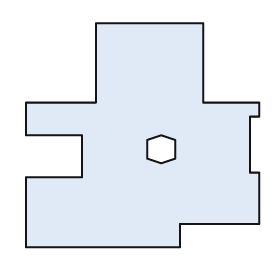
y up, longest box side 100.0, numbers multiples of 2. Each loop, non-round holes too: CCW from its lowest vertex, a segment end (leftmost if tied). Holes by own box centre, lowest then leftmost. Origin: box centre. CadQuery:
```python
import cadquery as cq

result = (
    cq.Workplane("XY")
    .moveTo(-50.0, -48.0)
    .lineTo(16.0, -48.0)
    .lineTo(16.0, -38.0)
    .lineTo(50.0, -38.0)
    .lineTo(50.0, -16.0)
    .lineTo(46.0, -16.0)
    .lineTo(46.0, 8.0)
    .lineTo(50.0, 8.0)
    .lineTo(50.0, 14.0)
    .lineTo(26.0, 14.0)
    .lineTo(26.0, 48.0)
    .lineTo(-20.0, 48.0)
    .lineTo(-20.0, 14.0)
    .lineTo(-50.0, 14.0)
    .lineTo(-50.0, 0.0)
    .lineTo(-26.0, 0.0)
    .lineTo(-26.0, -18.0)
    .lineTo(-50.0, -18.0)
    .close()
    .moveTo(8.0, -12.0)
    .lineTo(14.0, -10.0)
    .lineTo(14.0, -2.0)
    .lineTo(8.0, 0.0)
    .lineTo(2.0, -2.0)
    .lineTo(2.0, -10.0)
    .close()
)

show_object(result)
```